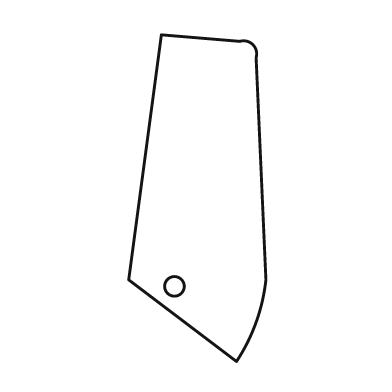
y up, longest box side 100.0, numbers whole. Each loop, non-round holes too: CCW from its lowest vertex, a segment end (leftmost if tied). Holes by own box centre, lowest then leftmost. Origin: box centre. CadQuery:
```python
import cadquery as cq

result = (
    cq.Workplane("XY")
    .moveTo(12.0, -50.0)
    .threePointArc((18.0, -38.0), (21.0, -25.0))
    .lineTo(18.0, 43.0)
    .threePointArc((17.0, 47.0), (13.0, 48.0))
    .lineTo(-11.0, 50.0)
    .lineTo(-21.0, -25.0)
    .close()
    .moveTo(-7.0, -27.0)
    .circle(3.0)
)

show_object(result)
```